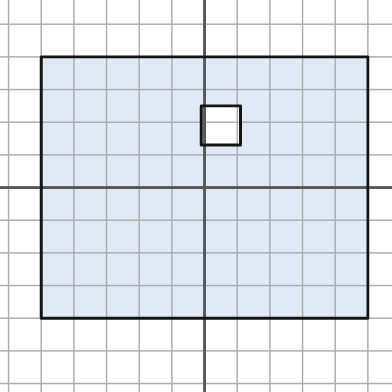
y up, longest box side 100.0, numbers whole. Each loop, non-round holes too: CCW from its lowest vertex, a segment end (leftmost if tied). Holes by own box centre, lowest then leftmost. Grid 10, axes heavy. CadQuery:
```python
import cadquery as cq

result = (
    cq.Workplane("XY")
    .moveTo(-50.0, -40.0)
    .lineTo(50.0, -40.0)
    .lineTo(50.0, 40.0)
    .lineTo(-50.0, 40.0)
    .close()
    .moveTo(-1.0, 13.0)
    .lineTo(11.0, 13.0)
    .lineTo(11.0, 25.0)
    .lineTo(-1.0, 25.0)
    .close()
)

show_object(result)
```